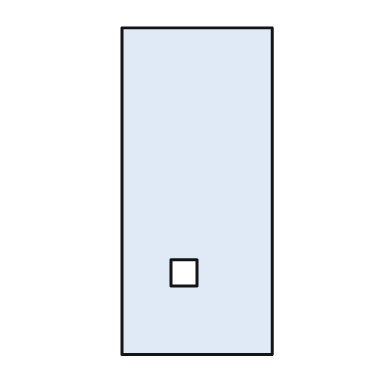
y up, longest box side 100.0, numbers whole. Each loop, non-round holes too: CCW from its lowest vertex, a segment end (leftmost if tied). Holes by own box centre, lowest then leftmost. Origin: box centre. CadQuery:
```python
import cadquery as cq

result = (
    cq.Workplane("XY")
    .moveTo(-23.0, -50.0)
    .lineTo(23.0, -50.0)
    .lineTo(23.0, 50.0)
    .lineTo(-23.0, 50.0)
    .close()
    .moveTo(-8.0, -29.0)
    .lineTo(0.0, -29.0)
    .lineTo(0.0, -21.0)
    .lineTo(-8.0, -21.0)
    .close()
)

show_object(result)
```